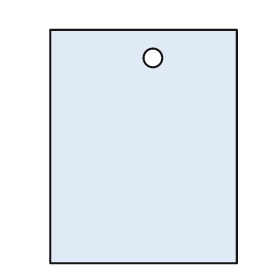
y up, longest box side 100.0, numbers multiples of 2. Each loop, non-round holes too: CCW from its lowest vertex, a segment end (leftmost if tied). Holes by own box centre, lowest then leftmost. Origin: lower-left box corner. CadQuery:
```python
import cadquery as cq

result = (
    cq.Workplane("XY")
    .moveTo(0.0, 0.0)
    .lineTo(80.0, 0.0)
    .lineTo(80.0, 100.0)
    .lineTo(0.0, 100.0)
    .close()
    .moveTo(44.0, 88.0)
    .circle(4.0)
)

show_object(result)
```